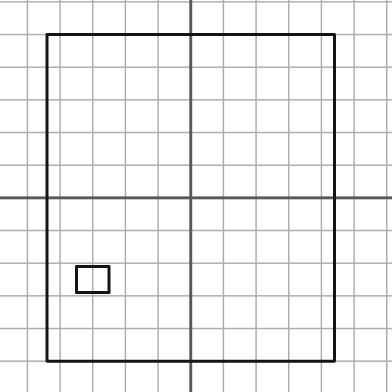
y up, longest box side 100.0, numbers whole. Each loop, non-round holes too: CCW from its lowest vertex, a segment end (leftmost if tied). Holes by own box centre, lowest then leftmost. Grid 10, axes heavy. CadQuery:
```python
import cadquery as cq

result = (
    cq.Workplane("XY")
    .moveTo(-44.0, -50.0)
    .lineTo(44.0, -50.0)
    .lineTo(44.0, 50.0)
    .lineTo(-44.0, 50.0)
    .close()
    .moveTo(-35.0, -29.0)
    .lineTo(-25.0, -29.0)
    .lineTo(-25.0, -21.0)
    .lineTo(-35.0, -21.0)
    .close()
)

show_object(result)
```